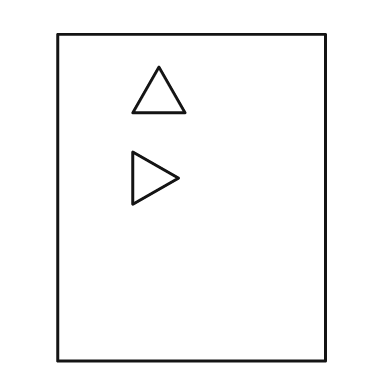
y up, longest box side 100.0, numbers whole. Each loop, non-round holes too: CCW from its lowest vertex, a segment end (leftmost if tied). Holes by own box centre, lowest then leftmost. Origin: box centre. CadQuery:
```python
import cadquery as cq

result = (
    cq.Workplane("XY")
    .moveTo(-41.0, -50.0)
    .lineTo(41.0, -50.0)
    .lineTo(41.0, 50.0)
    .lineTo(-41.0, 50.0)
    .close()
    .moveTo(-18.0, -2.0)
    .lineTo(-4.0, 6.0)
    .lineTo(-18.0, 14.0)
    .close()
    .moveTo(-18.0, 26.0)
    .lineTo(-2.0, 26.0)
    .lineTo(-10.0, 40.0)
    .close()
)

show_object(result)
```